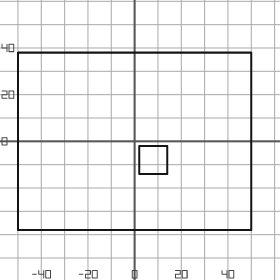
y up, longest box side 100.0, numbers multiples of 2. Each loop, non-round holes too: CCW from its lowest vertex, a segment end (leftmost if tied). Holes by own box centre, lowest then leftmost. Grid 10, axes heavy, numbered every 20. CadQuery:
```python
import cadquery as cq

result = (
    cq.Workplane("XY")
    .moveTo(-50.0, -38.0)
    .lineTo(50.0, -38.0)
    .lineTo(50.0, 38.0)
    .lineTo(-50.0, 38.0)
    .close()
    .moveTo(2.0, -14.0)
    .lineTo(14.0, -14.0)
    .lineTo(14.0, -2.0)
    .lineTo(2.0, -2.0)
    .close()
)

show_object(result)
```